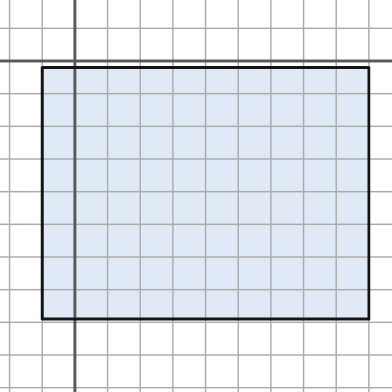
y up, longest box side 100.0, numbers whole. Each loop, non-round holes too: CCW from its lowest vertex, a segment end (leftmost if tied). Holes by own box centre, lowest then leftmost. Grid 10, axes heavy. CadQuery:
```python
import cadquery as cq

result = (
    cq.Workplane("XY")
    .moveTo(-10.0, -79.0)
    .lineTo(90.0, -79.0)
    .lineTo(90.0, -2.0)
    .lineTo(-10.0, -2.0)
    .close()
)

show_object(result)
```